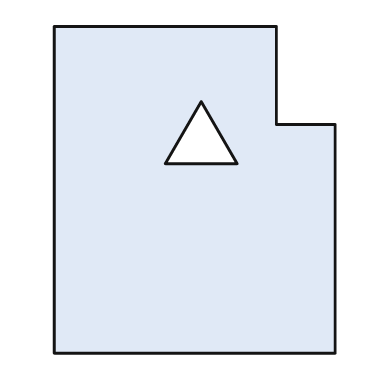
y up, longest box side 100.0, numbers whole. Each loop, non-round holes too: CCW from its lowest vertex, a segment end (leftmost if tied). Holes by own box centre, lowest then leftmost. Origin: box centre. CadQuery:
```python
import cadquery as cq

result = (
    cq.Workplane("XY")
    .moveTo(-43.0, -50.0)
    .lineTo(43.0, -50.0)
    .lineTo(43.0, 20.0)
    .lineTo(25.0, 20.0)
    .lineTo(25.0, 50.0)
    .lineTo(-43.0, 50.0)
    .close()
    .moveTo(-9.0, 8.0)
    .lineTo(13.0, 8.0)
    .lineTo(2.0, 27.0)
    .close()
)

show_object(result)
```